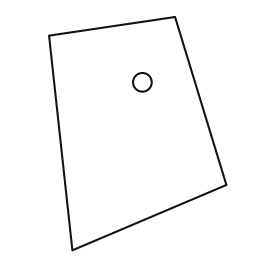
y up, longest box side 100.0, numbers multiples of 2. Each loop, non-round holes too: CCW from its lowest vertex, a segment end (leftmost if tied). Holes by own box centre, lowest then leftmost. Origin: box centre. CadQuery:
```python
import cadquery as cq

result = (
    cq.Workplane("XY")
    .moveTo(-28.0, -50.0)
    .lineTo(38.0, -22.0)
    .lineTo(16.0, 50.0)
    .lineTo(-38.0, 42.0)
    .close()
    .moveTo(2.0, 22.0)
    .circle(4.0)
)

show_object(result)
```